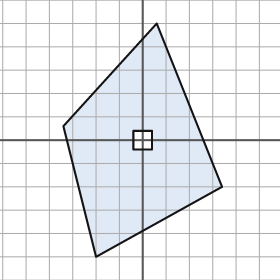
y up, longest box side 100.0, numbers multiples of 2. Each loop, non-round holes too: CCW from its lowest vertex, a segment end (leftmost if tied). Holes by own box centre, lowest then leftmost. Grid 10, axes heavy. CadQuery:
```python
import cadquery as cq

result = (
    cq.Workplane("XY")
    .moveTo(-20.0, -50.0)
    .lineTo(34.0, -20.0)
    .lineTo(6.0, 50.0)
    .lineTo(-34.0, 6.0)
    .close()
    .moveTo(-4.0, -4.0)
    .lineTo(4.0, -4.0)
    .lineTo(4.0, 4.0)
    .lineTo(-4.0, 4.0)
    .close()
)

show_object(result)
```